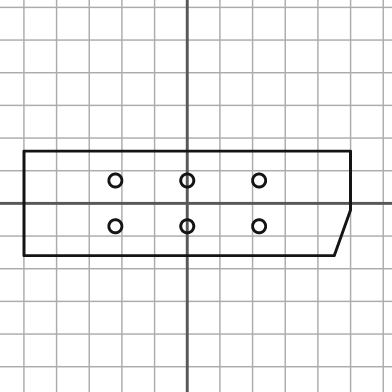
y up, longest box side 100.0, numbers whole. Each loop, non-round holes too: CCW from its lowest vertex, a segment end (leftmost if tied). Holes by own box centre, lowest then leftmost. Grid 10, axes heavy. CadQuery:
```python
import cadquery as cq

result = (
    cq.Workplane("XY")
    .moveTo(-50.0, -16.0)
    .lineTo(45.0, -16.0)
    .lineTo(50.0, -2.0)
    .lineTo(50.0, 16.0)
    .lineTo(-50.0, 16.0)
    .close()
    .moveTo(-22.0, -7.0)
    .circle(2.0)
    .moveTo(0.0, -7.0)
    .circle(2.0)
    .moveTo(22.0, -7.0)
    .circle(2.0)
    .moveTo(-22.0, 7.0)
    .circle(2.0)
    .moveTo(0.0, 7.0)
    .circle(2.0)
    .moveTo(22.0, 7.0)
    .circle(2.0)
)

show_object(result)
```